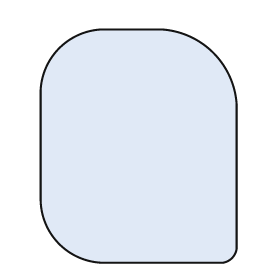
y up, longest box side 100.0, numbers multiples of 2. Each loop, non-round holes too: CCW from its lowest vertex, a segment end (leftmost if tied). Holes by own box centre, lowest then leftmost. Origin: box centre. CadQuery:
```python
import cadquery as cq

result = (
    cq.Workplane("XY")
    .moveTo(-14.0, -50.0)
    .lineTo(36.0, -50.0)
    .threePointArc((40.0, -48.0), (42.0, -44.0))
    .lineTo(42.0, 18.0)
    .threePointArc((32.0, 40.0), (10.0, 50.0))
    .lineTo(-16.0, 50.0)
    .threePointArc((-34.0, 42.0), (-42.0, 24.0))
    .lineTo(-42.0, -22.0)
    .threePointArc((-34.0, -42.0), (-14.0, -50.0))
    .close()
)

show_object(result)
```